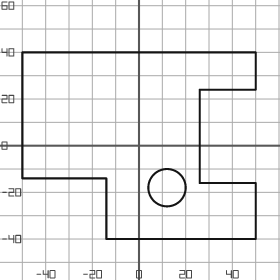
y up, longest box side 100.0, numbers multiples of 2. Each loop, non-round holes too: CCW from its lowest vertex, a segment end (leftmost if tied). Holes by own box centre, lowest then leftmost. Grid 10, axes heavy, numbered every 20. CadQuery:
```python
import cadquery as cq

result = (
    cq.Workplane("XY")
    .moveTo(-14.0, -40.0)
    .lineTo(50.0, -40.0)
    .lineTo(50.0, -16.0)
    .lineTo(26.0, -16.0)
    .lineTo(26.0, 24.0)
    .lineTo(50.0, 24.0)
    .lineTo(50.0, 40.0)
    .lineTo(-50.0, 40.0)
    .lineTo(-50.0, -14.0)
    .lineTo(-14.0, -14.0)
    .close()
    .moveTo(12.0, -18.0)
    .circle(8.0)
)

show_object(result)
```